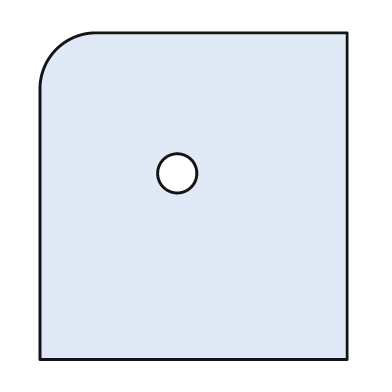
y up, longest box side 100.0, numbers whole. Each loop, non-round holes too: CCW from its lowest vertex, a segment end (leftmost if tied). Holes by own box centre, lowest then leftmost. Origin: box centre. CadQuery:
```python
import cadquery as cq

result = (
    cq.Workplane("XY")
    .moveTo(-47.0, -50.0)
    .lineTo(47.0, -50.0)
    .lineTo(47.0, 50.0)
    .lineTo(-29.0, 50.0)
    .threePointArc((-42.0, 45.0), (-47.0, 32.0))
    .close()
    .moveTo(-5.0, 7.0)
    .circle(6.0)
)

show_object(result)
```